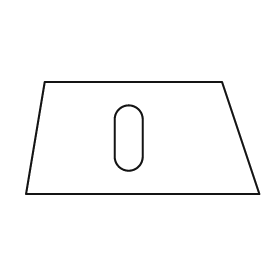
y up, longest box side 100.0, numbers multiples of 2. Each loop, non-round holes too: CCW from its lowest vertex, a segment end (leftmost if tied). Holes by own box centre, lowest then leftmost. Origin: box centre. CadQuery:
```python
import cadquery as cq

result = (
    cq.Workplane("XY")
    .moveTo(-50.0, -24.0)
    .lineTo(50.0, -24.0)
    .lineTo(34.0, 24.0)
    .lineTo(-42.0, 24.0)
    .close()
    .moveTo(-12.0, -8.0)
    .threePointArc((-6.0, -14.0), (0.0, -8.0))
    .lineTo(0.0, 8.0)
    .threePointArc((-6.0, 14.0), (-12.0, 8.0))
    .close()
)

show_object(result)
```